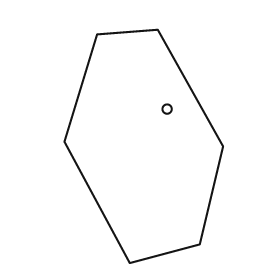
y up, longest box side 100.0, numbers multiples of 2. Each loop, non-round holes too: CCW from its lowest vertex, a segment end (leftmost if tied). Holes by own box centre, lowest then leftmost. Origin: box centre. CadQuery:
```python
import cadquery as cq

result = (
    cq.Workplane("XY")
    .moveTo(-6.0, -50.0)
    .lineTo(24.0, -42.0)
    .lineTo(34.0, 0.0)
    .lineTo(6.0, 50.0)
    .lineTo(-20.0, 48.0)
    .lineTo(-34.0, 2.0)
    .close()
    .moveTo(10.0, 16.0)
    .circle(2.0)
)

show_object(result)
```